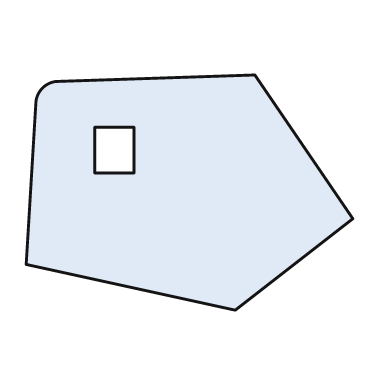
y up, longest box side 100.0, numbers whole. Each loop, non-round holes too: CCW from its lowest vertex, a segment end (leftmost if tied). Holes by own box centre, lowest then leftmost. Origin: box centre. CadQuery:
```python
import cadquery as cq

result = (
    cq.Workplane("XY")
    .moveTo(14.0, -36.0)
    .lineTo(50.0, -8.0)
    .lineTo(20.0, 36.0)
    .lineTo(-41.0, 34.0)
    .threePointArc((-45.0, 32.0), (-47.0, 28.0))
    .lineTo(-50.0, -22.0)
    .close()
    .moveTo(-29.0, 6.0)
    .lineTo(-17.0, 6.0)
    .lineTo(-17.0, 20.0)
    .lineTo(-29.0, 20.0)
    .close()
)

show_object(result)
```